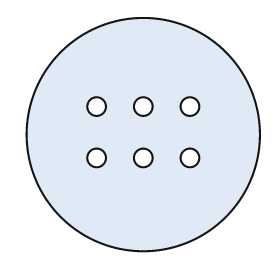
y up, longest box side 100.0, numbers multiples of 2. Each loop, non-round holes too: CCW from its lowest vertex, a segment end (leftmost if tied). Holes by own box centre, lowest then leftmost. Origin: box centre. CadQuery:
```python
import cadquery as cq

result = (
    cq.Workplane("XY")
    .moveTo(0.0, 0.0)
    .circle(50.0)
    .moveTo(-20.0, -10.0)
    .circle(4.0)
    .moveTo(0.0, -10.0)
    .circle(4.0)
    .moveTo(20.0, -10.0)
    .circle(4.0)
    .moveTo(-20.0, 12.0)
    .circle(4.0)
    .moveTo(0.0, 12.0)
    .circle(4.0)
    .moveTo(20.0, 12.0)
    .circle(4.0)
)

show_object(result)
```